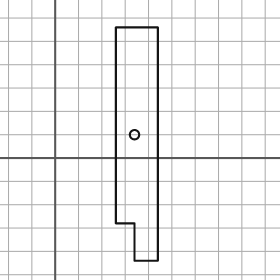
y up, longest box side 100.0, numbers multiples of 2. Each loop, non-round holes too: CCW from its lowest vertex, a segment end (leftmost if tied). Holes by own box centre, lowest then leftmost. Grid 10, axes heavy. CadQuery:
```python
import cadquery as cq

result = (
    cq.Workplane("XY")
    .moveTo(34.0, -44.0)
    .lineTo(44.0, -44.0)
    .lineTo(44.0, 56.0)
    .lineTo(26.0, 56.0)
    .lineTo(26.0, -28.0)
    .lineTo(34.0, -28.0)
    .close()
    .moveTo(34.0, 10.0)
    .circle(2.0)
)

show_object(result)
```